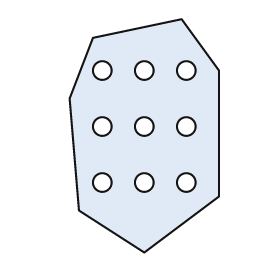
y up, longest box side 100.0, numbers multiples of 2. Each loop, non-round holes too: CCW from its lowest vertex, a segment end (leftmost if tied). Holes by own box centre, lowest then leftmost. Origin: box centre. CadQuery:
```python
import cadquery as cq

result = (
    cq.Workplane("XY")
    .moveTo(0.0, -50.0)
    .lineTo(32.0, -26.0)
    .lineTo(32.0, 28.0)
    .lineTo(16.0, 50.0)
    .lineTo(-22.0, 42.0)
    .lineTo(-32.0, 16.0)
    .lineTo(-28.0, -32.0)
    .close()
    .moveTo(-18.0, -20.0)
    .circle(4.0)
    .moveTo(0.0, -20.0)
    .circle(4.0)
    .moveTo(18.0, -20.0)
    .circle(4.0)
    .moveTo(-18.0, 4.0)
    .circle(4.0)
    .moveTo(0.0, 4.0)
    .circle(4.0)
    .moveTo(18.0, 4.0)
    .circle(4.0)
    .moveTo(-18.0, 28.0)
    .circle(4.0)
    .moveTo(0.0, 28.0)
    .circle(4.0)
    .moveTo(18.0, 28.0)
    .circle(4.0)
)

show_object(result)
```